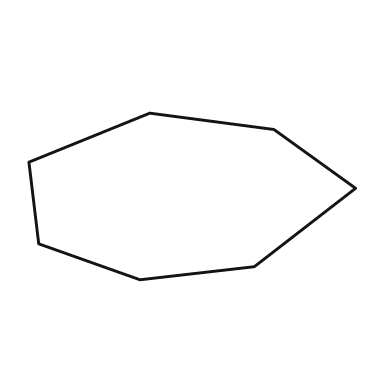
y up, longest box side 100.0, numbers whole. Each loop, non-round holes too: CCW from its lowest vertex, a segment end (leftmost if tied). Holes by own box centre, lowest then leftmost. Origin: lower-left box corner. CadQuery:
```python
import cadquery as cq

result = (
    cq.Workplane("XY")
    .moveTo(34.0, 0.0)
    .lineTo(69.0, 4.0)
    .lineTo(100.0, 28.0)
    .lineTo(75.0, 46.0)
    .lineTo(37.0, 51.0)
    .lineTo(0.0, 36.0)
    .lineTo(3.0, 11.0)
    .close()
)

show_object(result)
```